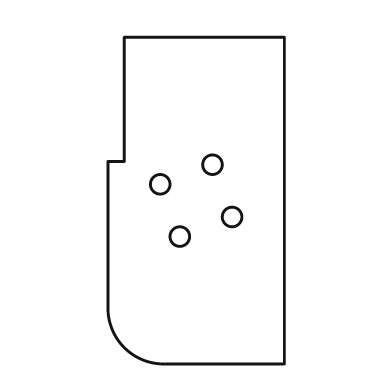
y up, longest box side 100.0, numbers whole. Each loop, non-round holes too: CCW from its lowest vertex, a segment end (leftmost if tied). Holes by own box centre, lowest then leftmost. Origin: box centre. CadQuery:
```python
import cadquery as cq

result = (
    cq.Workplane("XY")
    .moveTo(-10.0, -50.0)
    .lineTo(27.0, -50.0)
    .lineTo(27.0, 50.0)
    .lineTo(-22.0, 50.0)
    .lineTo(-22.0, 12.0)
    .lineTo(-27.0, 12.0)
    .lineTo(-27.0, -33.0)
    .threePointArc((-22.0, -45.0), (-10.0, -50.0))
    .close()
    .moveTo(-5.0, -11.0)
    .circle(3.0)
    .moveTo(11.0, -5.0)
    .circle(3.0)
    .moveTo(-11.0, 5.0)
    .circle(3.0)
    .moveTo(5.0, 11.0)
    .circle(3.0)
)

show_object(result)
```